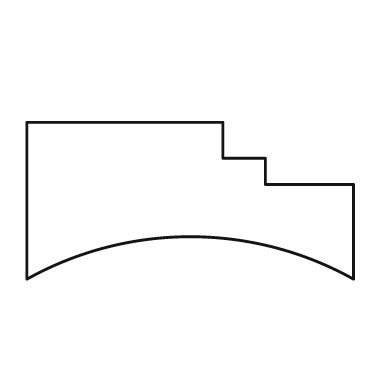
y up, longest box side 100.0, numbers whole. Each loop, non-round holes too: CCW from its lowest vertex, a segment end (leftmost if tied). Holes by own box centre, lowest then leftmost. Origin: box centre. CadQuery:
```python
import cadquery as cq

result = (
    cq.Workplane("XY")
    .moveTo(-50.0, -24.0)
    .threePointArc((0.0, -11.0), (50.0, -24.0))
    .lineTo(50.0, 5.0)
    .lineTo(23.0, 5.0)
    .lineTo(23.0, 13.0)
    .lineTo(10.0, 13.0)
    .lineTo(10.0, 24.0)
    .lineTo(-50.0, 24.0)
    .close()
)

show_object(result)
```